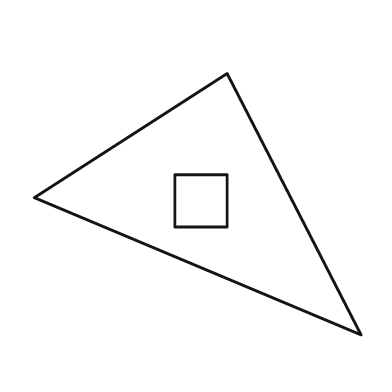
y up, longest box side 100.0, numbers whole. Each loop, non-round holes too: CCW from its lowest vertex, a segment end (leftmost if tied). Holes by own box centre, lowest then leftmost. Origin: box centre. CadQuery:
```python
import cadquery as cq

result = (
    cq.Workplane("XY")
    .moveTo(50.0, -40.0)
    .lineTo(9.0, 40.0)
    .lineTo(-50.0, 2.0)
    .close()
    .moveTo(-7.0, -7.0)
    .lineTo(9.0, -7.0)
    .lineTo(9.0, 9.0)
    .lineTo(-7.0, 9.0)
    .close()
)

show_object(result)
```